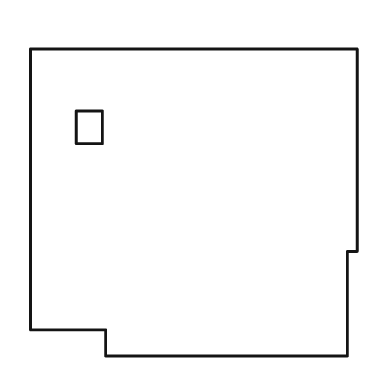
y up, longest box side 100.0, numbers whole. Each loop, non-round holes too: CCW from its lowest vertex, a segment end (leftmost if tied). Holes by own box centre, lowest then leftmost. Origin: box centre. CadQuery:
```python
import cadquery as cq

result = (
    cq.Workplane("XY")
    .moveTo(-27.0, -47.0)
    .lineTo(47.0, -47.0)
    .lineTo(47.0, -15.0)
    .lineTo(50.0, -15.0)
    .lineTo(50.0, 47.0)
    .lineTo(-50.0, 47.0)
    .lineTo(-50.0, -39.0)
    .lineTo(-27.0, -39.0)
    .close()
    .moveTo(-36.0, 18.0)
    .lineTo(-28.0, 18.0)
    .lineTo(-28.0, 28.0)
    .lineTo(-36.0, 28.0)
    .close()
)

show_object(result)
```